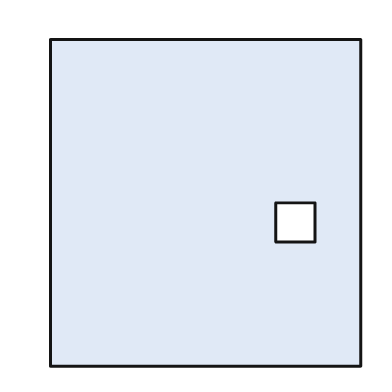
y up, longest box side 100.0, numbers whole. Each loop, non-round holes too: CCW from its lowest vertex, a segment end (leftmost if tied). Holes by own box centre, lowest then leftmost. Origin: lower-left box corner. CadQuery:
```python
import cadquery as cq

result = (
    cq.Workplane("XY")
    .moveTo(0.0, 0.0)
    .lineTo(95.0, 0.0)
    .lineTo(95.0, 100.0)
    .lineTo(0.0, 100.0)
    .close()
    .moveTo(69.0, 38.0)
    .lineTo(81.0, 38.0)
    .lineTo(81.0, 50.0)
    .lineTo(69.0, 50.0)
    .close()
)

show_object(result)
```